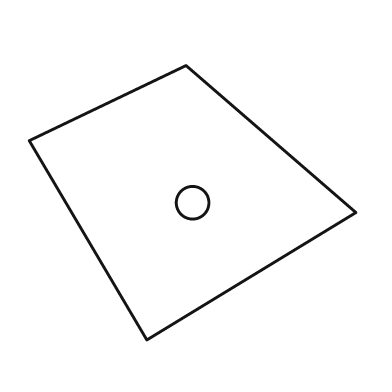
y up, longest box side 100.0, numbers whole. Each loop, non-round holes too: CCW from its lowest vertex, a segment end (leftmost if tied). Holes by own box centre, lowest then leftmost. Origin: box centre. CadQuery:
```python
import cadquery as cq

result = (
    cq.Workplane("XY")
    .moveTo(-14.0, -42.0)
    .lineTo(50.0, -3.0)
    .lineTo(-2.0, 42.0)
    .lineTo(-50.0, 19.0)
    .close()
    .moveTo(0.0, 0.0)
    .circle(5.0)
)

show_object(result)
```